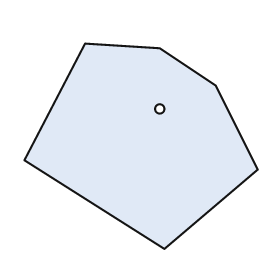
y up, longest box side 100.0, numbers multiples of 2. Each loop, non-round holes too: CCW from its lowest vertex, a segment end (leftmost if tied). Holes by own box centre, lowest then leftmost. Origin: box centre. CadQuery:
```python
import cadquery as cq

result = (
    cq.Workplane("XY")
    .moveTo(10.0, -44.0)
    .lineTo(50.0, -10.0)
    .lineTo(32.0, 26.0)
    .lineTo(8.0, 42.0)
    .lineTo(-24.0, 44.0)
    .lineTo(-50.0, -6.0)
    .close()
    .moveTo(8.0, 16.0)
    .circle(2.0)
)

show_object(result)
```